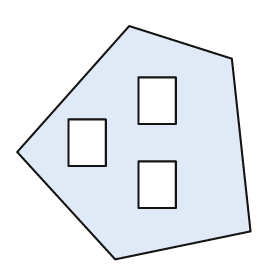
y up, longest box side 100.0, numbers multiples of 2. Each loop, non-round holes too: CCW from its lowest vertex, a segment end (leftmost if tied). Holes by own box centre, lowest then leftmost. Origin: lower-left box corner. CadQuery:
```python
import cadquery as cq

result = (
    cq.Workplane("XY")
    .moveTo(42.0, 0.0)
    .lineTo(100.0, 12.0)
    .lineTo(92.0, 86.0)
    .lineTo(48.0, 100.0)
    .lineTo(0.0, 46.0)
    .close()
    .moveTo(52.0, 22.0)
    .lineTo(68.0, 22.0)
    .lineTo(68.0, 42.0)
    .lineTo(52.0, 42.0)
    .close()
    .moveTo(22.0, 40.0)
    .lineTo(38.0, 40.0)
    .lineTo(38.0, 60.0)
    .lineTo(22.0, 60.0)
    .close()
    .moveTo(52.0, 58.0)
    .lineTo(68.0, 58.0)
    .lineTo(68.0, 78.0)
    .lineTo(52.0, 78.0)
    .close()
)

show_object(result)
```